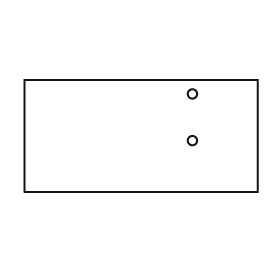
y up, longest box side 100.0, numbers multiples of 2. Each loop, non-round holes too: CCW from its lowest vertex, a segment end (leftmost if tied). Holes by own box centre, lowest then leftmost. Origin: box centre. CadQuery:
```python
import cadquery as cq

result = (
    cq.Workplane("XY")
    .moveTo(-50.0, -24.0)
    .lineTo(50.0, -24.0)
    .lineTo(50.0, 24.0)
    .lineTo(-50.0, 24.0)
    .close()
    .moveTo(22.0, -2.0)
    .circle(2.0)
    .moveTo(22.0, 18.0)
    .circle(2.0)
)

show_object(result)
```